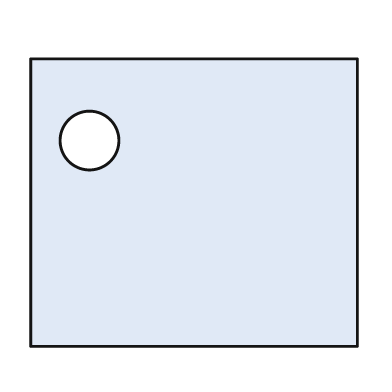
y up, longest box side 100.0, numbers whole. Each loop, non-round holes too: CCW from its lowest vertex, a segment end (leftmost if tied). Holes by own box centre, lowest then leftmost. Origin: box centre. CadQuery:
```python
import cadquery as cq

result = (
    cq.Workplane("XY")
    .moveTo(-50.0, -44.0)
    .lineTo(50.0, -44.0)
    .lineTo(50.0, 44.0)
    .lineTo(-50.0, 44.0)
    .close()
    .moveTo(-32.0, 19.0)
    .circle(9.0)
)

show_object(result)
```